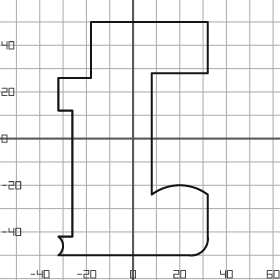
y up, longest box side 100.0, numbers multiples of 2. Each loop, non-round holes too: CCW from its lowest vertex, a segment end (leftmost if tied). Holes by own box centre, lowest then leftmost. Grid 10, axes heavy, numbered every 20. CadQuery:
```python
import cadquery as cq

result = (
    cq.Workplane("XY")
    .moveTo(-32.0, -50.0)
    .lineTo(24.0, -50.0)
    .threePointArc((30.0, -48.0), (32.0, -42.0))
    .lineTo(32.0, -24.0)
    .threePointArc((20.0, -20.0), (8.0, -24.0))
    .lineTo(8.0, 28.0)
    .lineTo(32.0, 28.0)
    .lineTo(32.0, 50.0)
    .lineTo(-18.0, 50.0)
    .lineTo(-18.0, 26.0)
    .lineTo(-32.0, 26.0)
    .lineTo(-32.0, 12.0)
    .lineTo(-26.0, 12.0)
    .lineTo(-26.0, -42.0)
    .lineTo(-32.0, -42.0)
    .threePointArc((-30.0, -46.0), (-32.0, -50.0))
    .close()
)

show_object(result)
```